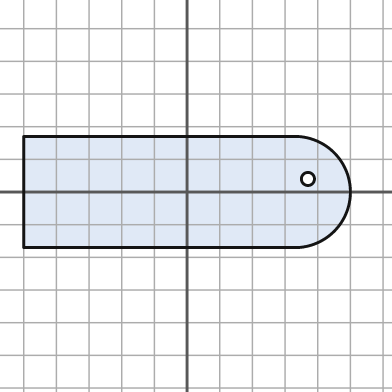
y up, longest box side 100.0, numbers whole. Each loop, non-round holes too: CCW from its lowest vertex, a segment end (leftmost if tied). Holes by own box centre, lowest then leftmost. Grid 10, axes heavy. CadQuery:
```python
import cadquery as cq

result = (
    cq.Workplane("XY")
    .moveTo(-50.0, -17.0)
    .lineTo(34.0, -17.0)
    .threePointArc((50.0, 0.0), (34.0, 17.0))
    .lineTo(-50.0, 17.0)
    .close()
    .moveTo(37.0, 4.0)
    .circle(2.0)
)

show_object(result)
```